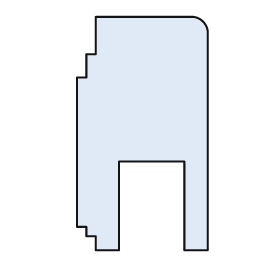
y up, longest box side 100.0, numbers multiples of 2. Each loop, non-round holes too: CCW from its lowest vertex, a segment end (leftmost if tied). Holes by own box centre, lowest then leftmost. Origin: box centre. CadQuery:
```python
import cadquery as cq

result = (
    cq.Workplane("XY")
    .moveTo(-20.0, -50.0)
    .lineTo(-10.0, -50.0)
    .lineTo(-10.0, -12.0)
    .lineTo(18.0, -12.0)
    .lineTo(18.0, -50.0)
    .lineTo(28.0, -50.0)
    .lineTo(28.0, 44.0)
    .threePointArc((26.0, 48.0), (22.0, 50.0))
    .lineTo(-20.0, 50.0)
    .lineTo(-20.0, 34.0)
    .lineTo(-24.0, 34.0)
    .lineTo(-24.0, 24.0)
    .lineTo(-28.0, 24.0)
    .lineTo(-28.0, -40.0)
    .lineTo(-24.0, -40.0)
    .lineTo(-24.0, -44.0)
    .lineTo(-20.0, -44.0)
    .close()
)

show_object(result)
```